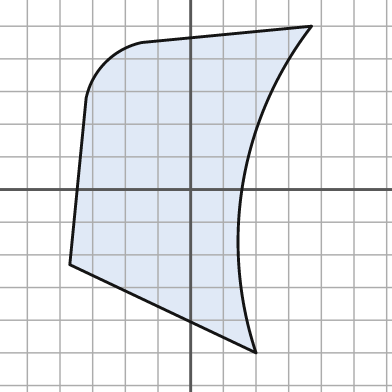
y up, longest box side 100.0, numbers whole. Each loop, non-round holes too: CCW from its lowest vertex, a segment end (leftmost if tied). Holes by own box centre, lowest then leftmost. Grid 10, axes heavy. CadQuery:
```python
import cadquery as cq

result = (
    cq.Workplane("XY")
    .moveTo(20.0, -50.0)
    .threePointArc((16.0, 2.0), (37.0, 50.0))
    .lineTo(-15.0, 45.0)
    .threePointArc((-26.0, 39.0), (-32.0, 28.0))
    .lineTo(-37.0, -23.0)
    .close()
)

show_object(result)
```